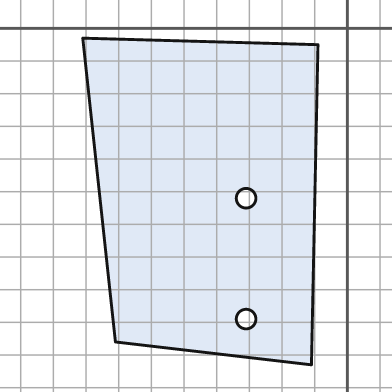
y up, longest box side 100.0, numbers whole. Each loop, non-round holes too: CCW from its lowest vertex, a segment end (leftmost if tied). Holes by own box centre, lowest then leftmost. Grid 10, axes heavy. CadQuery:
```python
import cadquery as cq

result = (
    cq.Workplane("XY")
    .moveTo(-11.0, -103.0)
    .lineTo(-9.0, -5.0)
    .lineTo(-81.0, -3.0)
    .lineTo(-71.0, -96.0)
    .close()
    .moveTo(-31.0, -89.0)
    .circle(3.0)
    .moveTo(-31.0, -52.0)
    .circle(3.0)
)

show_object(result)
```